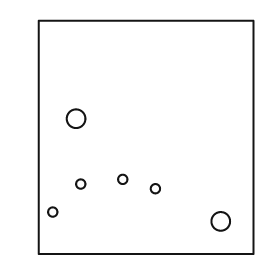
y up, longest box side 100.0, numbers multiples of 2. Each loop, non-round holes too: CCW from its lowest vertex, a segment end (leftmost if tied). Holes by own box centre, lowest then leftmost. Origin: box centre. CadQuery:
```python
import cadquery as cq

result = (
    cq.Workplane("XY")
    .moveTo(-46.0, -50.0)
    .lineTo(46.0, -50.0)
    .lineTo(46.0, 50.0)
    .lineTo(-46.0, 50.0)
    .close()
    .moveTo(32.0, -36.0)
    .circle(4.0)
    .moveTo(-40.0, -32.0)
    .circle(2.0)
    .moveTo(4.0, -22.0)
    .circle(2.0)
    .moveTo(-28.0, -20.0)
    .circle(2.0)
    .moveTo(-10.0, -18.0)
    .circle(2.0)
    .moveTo(-30.0, 8.0)
    .circle(4.0)
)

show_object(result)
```